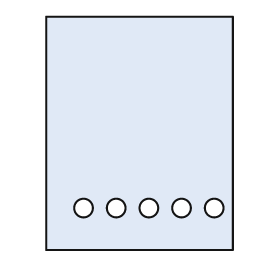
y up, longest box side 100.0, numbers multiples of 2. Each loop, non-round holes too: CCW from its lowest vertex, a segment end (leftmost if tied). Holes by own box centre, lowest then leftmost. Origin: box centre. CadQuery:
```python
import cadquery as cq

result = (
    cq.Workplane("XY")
    .moveTo(-40.0, -50.0)
    .lineTo(40.0, -50.0)
    .lineTo(40.0, 50.0)
    .lineTo(-40.0, 50.0)
    .close()
    .moveTo(-24.0, -32.0)
    .circle(4.0)
    .moveTo(-10.0, -32.0)
    .circle(4.0)
    .moveTo(4.0, -32.0)
    .circle(4.0)
    .moveTo(18.0, -32.0)
    .circle(4.0)
    .moveTo(32.0, -32.0)
    .circle(4.0)
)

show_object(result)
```